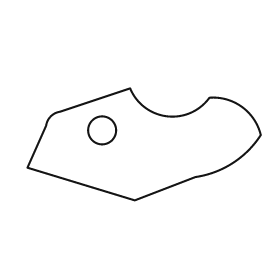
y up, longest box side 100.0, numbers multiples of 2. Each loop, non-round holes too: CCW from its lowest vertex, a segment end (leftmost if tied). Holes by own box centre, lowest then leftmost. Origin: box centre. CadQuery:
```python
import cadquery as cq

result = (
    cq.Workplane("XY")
    .moveTo(-4.0, -24.0)
    .lineTo(22.0, -14.0)
    .threePointArc((38.0, -8.0), (50.0, 4.0))
    .threePointArc((42.0, 16.0), (28.0, 20.0))
    .threePointArc((10.0, 12.0), (-6.0, 24.0))
    .lineTo(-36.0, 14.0)
    .threePointArc((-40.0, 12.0), (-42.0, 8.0))
    .lineTo(-50.0, -10.0)
    .close()
    .moveTo(-18.0, 6.0)
    .circle(6.0)
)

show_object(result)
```